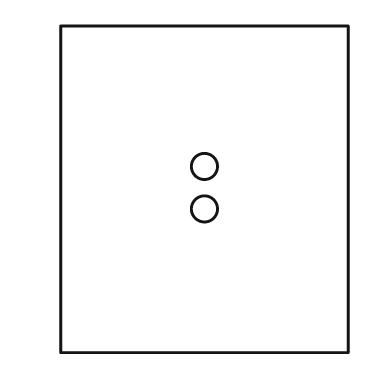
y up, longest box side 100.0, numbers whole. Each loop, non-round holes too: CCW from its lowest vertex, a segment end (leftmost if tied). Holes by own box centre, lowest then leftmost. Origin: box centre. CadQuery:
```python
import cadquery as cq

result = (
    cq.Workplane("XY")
    .moveTo(-44.0, -50.0)
    .lineTo(44.0, -50.0)
    .lineTo(44.0, 50.0)
    .lineTo(-44.0, 50.0)
    .close()
    .moveTo(0.0, -6.0)
    .circle(4.0)
    .moveTo(0.0, 7.0)
    .circle(4.0)
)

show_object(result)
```